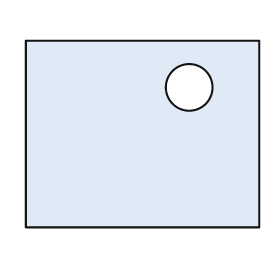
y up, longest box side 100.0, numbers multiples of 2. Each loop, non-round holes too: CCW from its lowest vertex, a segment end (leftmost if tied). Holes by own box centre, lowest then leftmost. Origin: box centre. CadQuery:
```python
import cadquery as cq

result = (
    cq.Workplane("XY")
    .moveTo(-50.0, -40.0)
    .lineTo(50.0, -40.0)
    .lineTo(50.0, 40.0)
    .lineTo(-50.0, 40.0)
    .close()
    .moveTo(20.0, 20.0)
    .circle(10.0)
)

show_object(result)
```